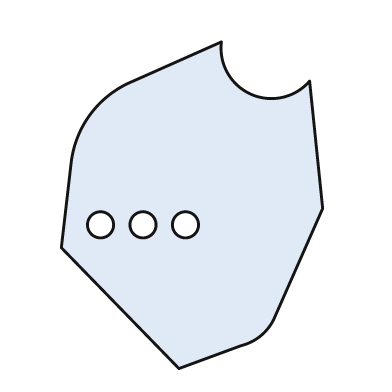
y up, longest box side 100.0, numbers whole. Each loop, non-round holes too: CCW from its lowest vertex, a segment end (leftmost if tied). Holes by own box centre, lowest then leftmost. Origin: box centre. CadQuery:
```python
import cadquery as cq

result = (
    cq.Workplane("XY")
    .moveTo(-4.0, -50.0)
    .lineTo(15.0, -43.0)
    .threePointArc((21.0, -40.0), (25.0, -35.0))
    .lineTo(40.0, -1.0)
    .lineTo(36.0, 38.0)
    .threePointArc((18.0, 34.0), (9.0, 50.0))
    .lineTo(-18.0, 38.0)
    .threePointArc((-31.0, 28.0), (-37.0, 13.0))
    .lineTo(-40.0, -13.0)
    .close()
    .moveTo(-28.0, -6.0)
    .circle(4.0)
    .moveTo(-15.0, -6.0)
    .circle(4.0)
    .moveTo(-2.0, -6.0)
    .circle(4.0)
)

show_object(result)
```